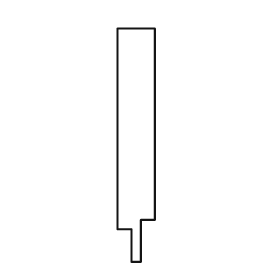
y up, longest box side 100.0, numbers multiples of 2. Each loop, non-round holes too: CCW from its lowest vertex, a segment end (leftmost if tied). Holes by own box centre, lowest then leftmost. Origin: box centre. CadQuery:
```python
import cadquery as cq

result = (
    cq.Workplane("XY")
    .moveTo(-2.0, -50.0)
    .lineTo(2.0, -50.0)
    .lineTo(2.0, -32.0)
    .lineTo(8.0, -32.0)
    .lineTo(8.0, 50.0)
    .lineTo(-8.0, 50.0)
    .lineTo(-8.0, -36.0)
    .lineTo(-2.0, -36.0)
    .close()
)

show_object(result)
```